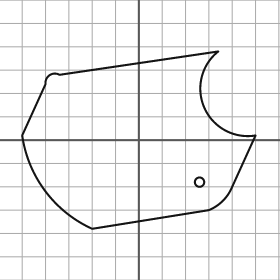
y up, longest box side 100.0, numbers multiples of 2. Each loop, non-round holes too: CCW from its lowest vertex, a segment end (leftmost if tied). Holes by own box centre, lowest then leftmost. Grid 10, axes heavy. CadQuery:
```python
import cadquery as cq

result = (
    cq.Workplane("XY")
    .moveTo(-20.0, -38.0)
    .lineTo(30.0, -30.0)
    .threePointArc((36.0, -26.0), (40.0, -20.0))
    .lineTo(50.0, 2.0)
    .threePointArc((28.0, 14.0), (34.0, 38.0))
    .lineTo(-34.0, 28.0)
    .threePointArc((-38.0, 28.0), (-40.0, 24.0))
    .lineTo(-50.0, 2.0)
    .threePointArc((-40.0, -22.0), (-20.0, -38.0))
    .close()
    .moveTo(26.0, -18.0)
    .circle(2.0)
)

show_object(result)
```